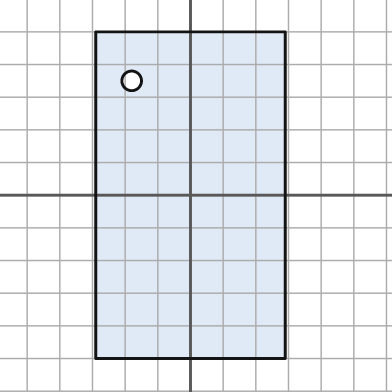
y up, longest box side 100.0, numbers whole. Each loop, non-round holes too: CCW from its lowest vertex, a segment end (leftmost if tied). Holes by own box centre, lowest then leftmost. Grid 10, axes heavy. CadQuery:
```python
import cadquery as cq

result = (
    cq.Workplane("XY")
    .moveTo(-29.0, -50.0)
    .lineTo(29.0, -50.0)
    .lineTo(29.0, 50.0)
    .lineTo(-29.0, 50.0)
    .close()
    .moveTo(-18.0, 35.0)
    .circle(3.0)
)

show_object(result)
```